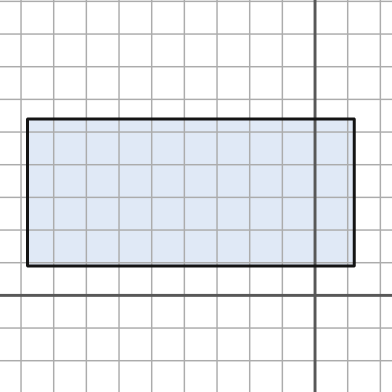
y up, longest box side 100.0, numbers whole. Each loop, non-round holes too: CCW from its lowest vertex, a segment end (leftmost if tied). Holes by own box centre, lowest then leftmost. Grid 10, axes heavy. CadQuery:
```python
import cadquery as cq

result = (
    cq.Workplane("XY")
    .moveTo(-88.0, 9.0)
    .lineTo(12.0, 9.0)
    .lineTo(12.0, 54.0)
    .lineTo(-88.0, 54.0)
    .close()
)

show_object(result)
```